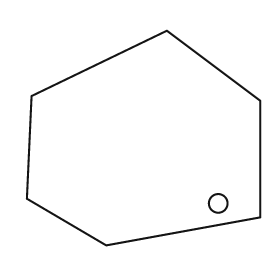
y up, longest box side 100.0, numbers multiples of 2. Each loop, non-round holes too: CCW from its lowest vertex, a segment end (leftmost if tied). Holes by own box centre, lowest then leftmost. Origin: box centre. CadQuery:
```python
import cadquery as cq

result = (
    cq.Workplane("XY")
    .moveTo(-16.0, -46.0)
    .lineTo(50.0, -34.0)
    .lineTo(50.0, 16.0)
    .lineTo(10.0, 46.0)
    .lineTo(-48.0, 18.0)
    .lineTo(-50.0, -26.0)
    .close()
    .moveTo(32.0, -28.0)
    .circle(4.0)
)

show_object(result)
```